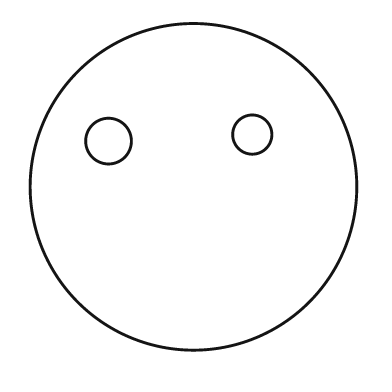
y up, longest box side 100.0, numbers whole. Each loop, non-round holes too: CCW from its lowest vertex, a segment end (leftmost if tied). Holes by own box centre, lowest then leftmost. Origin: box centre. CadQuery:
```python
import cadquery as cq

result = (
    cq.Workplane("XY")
    .moveTo(0.0, 0.0)
    .circle(50.0)
    .moveTo(-26.0, 14.0)
    .circle(7.0)
    .moveTo(18.0, 16.0)
    .circle(6.0)
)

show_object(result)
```